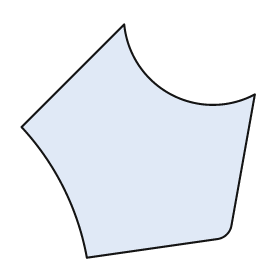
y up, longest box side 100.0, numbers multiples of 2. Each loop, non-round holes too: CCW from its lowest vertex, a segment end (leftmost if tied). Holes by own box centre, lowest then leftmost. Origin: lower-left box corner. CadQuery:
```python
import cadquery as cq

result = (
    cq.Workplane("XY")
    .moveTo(28.0, 0.0)
    .lineTo(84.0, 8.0)
    .threePointArc((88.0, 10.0), (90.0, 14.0))
    .lineTo(100.0, 70.0)
    .threePointArc((64.0, 70.0), (44.0, 100.0))
    .lineTo(0.0, 56.0)
    .threePointArc((18.0, 30.0), (28.0, 0.0))
    .close()
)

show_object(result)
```